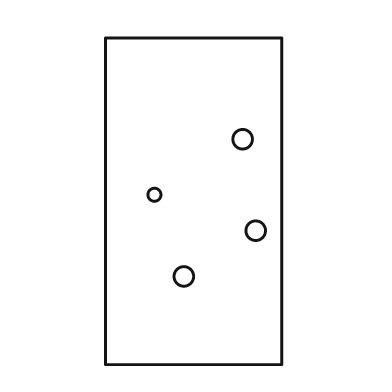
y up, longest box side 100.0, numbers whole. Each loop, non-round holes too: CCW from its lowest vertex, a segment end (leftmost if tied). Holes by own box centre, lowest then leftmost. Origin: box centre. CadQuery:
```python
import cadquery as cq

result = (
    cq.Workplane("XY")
    .moveTo(-27.0, -50.0)
    .lineTo(27.0, -50.0)
    .lineTo(27.0, 50.0)
    .lineTo(-27.0, 50.0)
    .close()
    .moveTo(-3.0, -23.0)
    .circle(3.0)
    .moveTo(19.0, -9.0)
    .circle(3.0)
    .moveTo(-12.0, 2.0)
    .circle(2.0)
    .moveTo(15.0, 19.0)
    .circle(3.0)
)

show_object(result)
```